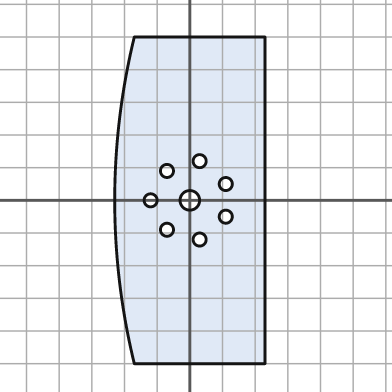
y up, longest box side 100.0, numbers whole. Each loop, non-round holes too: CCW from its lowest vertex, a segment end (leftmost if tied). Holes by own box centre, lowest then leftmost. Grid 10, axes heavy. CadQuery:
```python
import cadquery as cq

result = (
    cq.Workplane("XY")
    .moveTo(-17.0, -50.0)
    .lineTo(23.0, -50.0)
    .lineTo(23.0, 50.0)
    .lineTo(-17.0, 50.0)
    .threePointArc((-23.0, 0.0), (-17.0, -50.0))
    .close()
    .moveTo(3.0, -12.0)
    .circle(2.0)
    .moveTo(-7.0, -9.0)
    .circle(2.0)
    .moveTo(11.0, -5.0)
    .circle(2.0)
    .moveTo(-12.0, 0.0)
    .circle(2.0)
    .moveTo(0.0, 0.0)
    .circle(3.0)
    .moveTo(11.0, 5.0)
    .circle(2.0)
    .moveTo(-7.0, 9.0)
    .circle(2.0)
    .moveTo(3.0, 12.0)
    .circle(2.0)
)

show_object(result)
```